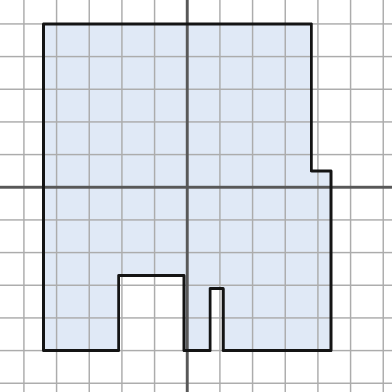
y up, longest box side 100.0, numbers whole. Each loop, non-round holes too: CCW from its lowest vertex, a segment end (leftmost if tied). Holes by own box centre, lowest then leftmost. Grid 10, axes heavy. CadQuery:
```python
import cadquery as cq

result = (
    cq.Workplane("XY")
    .moveTo(-44.0, -50.0)
    .lineTo(-21.0, -50.0)
    .lineTo(-21.0, -27.0)
    .lineTo(-1.0, -27.0)
    .lineTo(-1.0, -50.0)
    .lineTo(7.0, -50.0)
    .lineTo(7.0, -31.0)
    .lineTo(11.0, -31.0)
    .lineTo(11.0, -50.0)
    .lineTo(44.0, -50.0)
    .lineTo(44.0, 5.0)
    .lineTo(38.0, 5.0)
    .lineTo(38.0, 50.0)
    .lineTo(-44.0, 50.0)
    .close()
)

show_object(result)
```